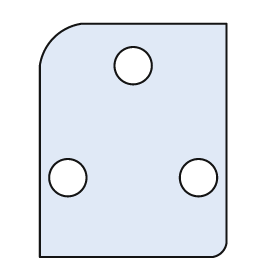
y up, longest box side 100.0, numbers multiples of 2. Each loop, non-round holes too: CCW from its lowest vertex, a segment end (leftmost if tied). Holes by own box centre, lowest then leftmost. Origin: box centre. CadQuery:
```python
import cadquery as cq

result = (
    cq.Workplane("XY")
    .moveTo(-40.0, -50.0)
    .lineTo(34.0, -50.0)
    .threePointArc((38.0, -48.0), (40.0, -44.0))
    .lineTo(40.0, 50.0)
    .lineTo(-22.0, 50.0)
    .threePointArc((-34.0, 44.0), (-40.0, 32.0))
    .close()
    .moveTo(-28.0, -16.0)
    .circle(8.0)
    .moveTo(28.0, -16.0)
    .circle(8.0)
    .moveTo(0.0, 32.0)
    .circle(8.0)
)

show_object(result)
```